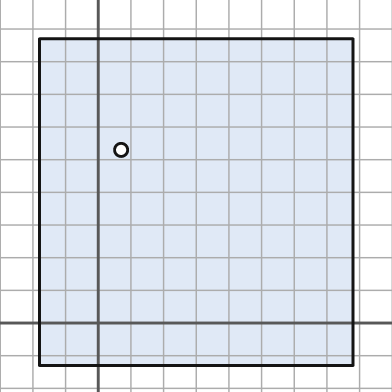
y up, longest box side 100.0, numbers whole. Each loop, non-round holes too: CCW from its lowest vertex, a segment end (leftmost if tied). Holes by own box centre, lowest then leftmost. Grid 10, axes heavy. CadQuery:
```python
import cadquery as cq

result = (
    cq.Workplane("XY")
    .moveTo(-18.0, -13.0)
    .lineTo(78.0, -13.0)
    .lineTo(78.0, 87.0)
    .lineTo(-18.0, 87.0)
    .close()
    .moveTo(7.0, 53.0)
    .circle(2.0)
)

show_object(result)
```